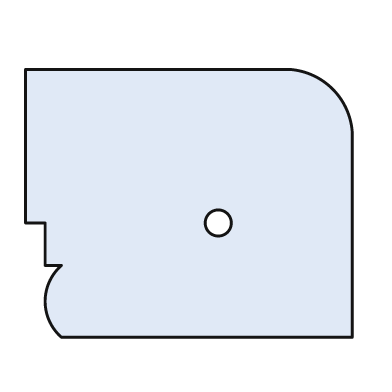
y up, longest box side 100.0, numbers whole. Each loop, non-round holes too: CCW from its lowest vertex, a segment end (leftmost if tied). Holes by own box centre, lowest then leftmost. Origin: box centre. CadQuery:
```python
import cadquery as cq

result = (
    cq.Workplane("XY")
    .moveTo(-39.0, -41.0)
    .lineTo(50.0, -41.0)
    .lineTo(50.0, 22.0)
    .threePointArc((44.0, 35.0), (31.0, 41.0))
    .lineTo(-50.0, 41.0)
    .lineTo(-50.0, -6.0)
    .lineTo(-44.0, -6.0)
    .lineTo(-44.0, -19.0)
    .lineTo(-39.0, -19.0)
    .threePointArc((-44.0, -30.0), (-39.0, -41.0))
    .close()
    .moveTo(9.0, -6.0)
    .circle(4.0)
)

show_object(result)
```